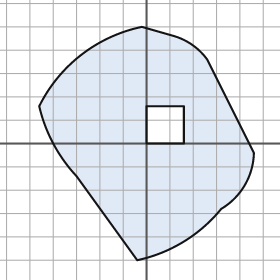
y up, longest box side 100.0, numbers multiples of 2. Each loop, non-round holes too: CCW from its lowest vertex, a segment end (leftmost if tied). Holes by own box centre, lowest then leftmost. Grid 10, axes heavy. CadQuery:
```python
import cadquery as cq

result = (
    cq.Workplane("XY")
    .moveTo(-4.0, -50.0)
    .threePointArc((16.0, -42.0), (32.0, -28.0))
    .threePointArc((42.0, -18.0), (46.0, -4.0))
    .lineTo(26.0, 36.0)
    .threePointArc((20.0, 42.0), (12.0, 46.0))
    .lineTo(-2.0, 50.0)
    .threePointArc((-28.0, 38.0), (-46.0, 16.0))
    .threePointArc((-40.0, 0.0), (-30.0, -14.0))
    .close()
    .moveTo(0.0, 0.0)
    .lineTo(16.0, 0.0)
    .lineTo(16.0, 16.0)
    .lineTo(0.0, 16.0)
    .close()
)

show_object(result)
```